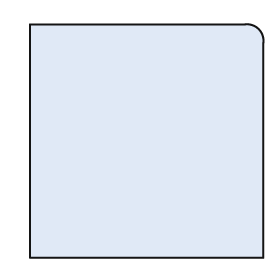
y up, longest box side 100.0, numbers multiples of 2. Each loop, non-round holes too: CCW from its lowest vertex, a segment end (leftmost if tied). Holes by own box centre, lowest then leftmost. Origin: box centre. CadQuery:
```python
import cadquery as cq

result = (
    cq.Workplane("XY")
    .moveTo(-50.0, -50.0)
    .lineTo(50.0, -50.0)
    .lineTo(50.0, 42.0)
    .threePointArc((48.0, 48.0), (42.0, 50.0))
    .lineTo(-50.0, 50.0)
    .close()
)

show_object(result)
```